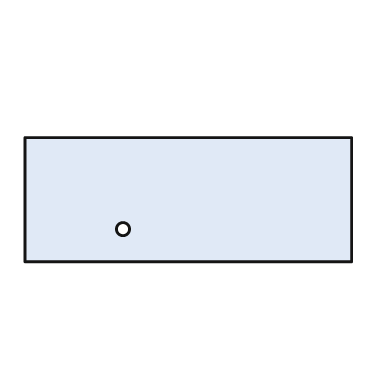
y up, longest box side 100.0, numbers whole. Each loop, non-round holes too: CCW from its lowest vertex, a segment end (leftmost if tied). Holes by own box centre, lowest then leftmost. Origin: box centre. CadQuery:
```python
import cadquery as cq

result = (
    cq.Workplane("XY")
    .moveTo(-50.0, -19.0)
    .lineTo(50.0, -19.0)
    .lineTo(50.0, 19.0)
    .lineTo(-50.0, 19.0)
    .close()
    .moveTo(-20.0, -9.0)
    .circle(2.0)
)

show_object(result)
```